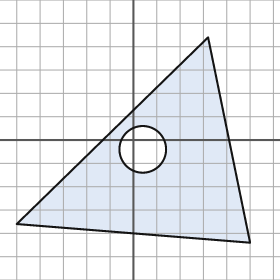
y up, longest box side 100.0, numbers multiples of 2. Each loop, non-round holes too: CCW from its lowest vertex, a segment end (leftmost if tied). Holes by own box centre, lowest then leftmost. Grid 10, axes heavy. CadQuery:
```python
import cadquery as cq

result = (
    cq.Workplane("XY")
    .moveTo(50.0, -44.0)
    .lineTo(32.0, 44.0)
    .lineTo(-50.0, -36.0)
    .close()
    .moveTo(4.0, -4.0)
    .circle(10.0)
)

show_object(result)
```